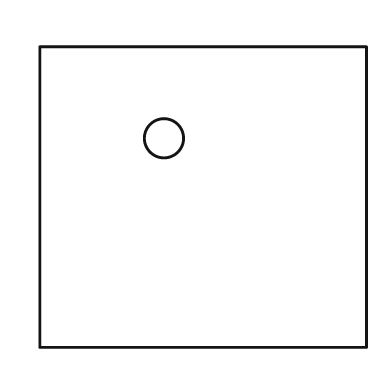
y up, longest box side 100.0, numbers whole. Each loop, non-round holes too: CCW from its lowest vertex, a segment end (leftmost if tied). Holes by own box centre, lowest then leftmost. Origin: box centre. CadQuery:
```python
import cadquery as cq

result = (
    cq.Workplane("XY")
    .moveTo(-50.0, -46.0)
    .lineTo(50.0, -46.0)
    .lineTo(50.0, 46.0)
    .lineTo(-50.0, 46.0)
    .close()
    .moveTo(-12.0, 18.0)
    .circle(6.0)
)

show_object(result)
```